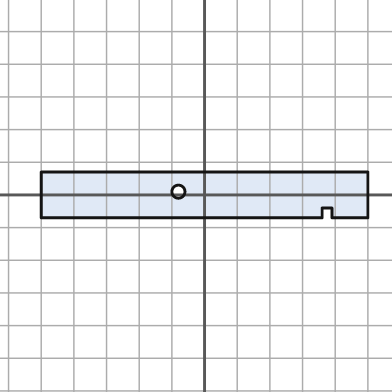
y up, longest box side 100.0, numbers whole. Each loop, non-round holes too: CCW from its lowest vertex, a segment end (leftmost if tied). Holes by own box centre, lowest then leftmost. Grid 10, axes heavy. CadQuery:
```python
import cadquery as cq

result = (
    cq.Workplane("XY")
    .moveTo(-50.0, -7.0)
    .lineTo(36.0, -7.0)
    .lineTo(36.0, -4.0)
    .lineTo(39.0, -4.0)
    .lineTo(39.0, -7.0)
    .lineTo(50.0, -7.0)
    .lineTo(50.0, 7.0)
    .lineTo(-50.0, 7.0)
    .close()
    .moveTo(-8.0, 1.0)
    .circle(2.0)
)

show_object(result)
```